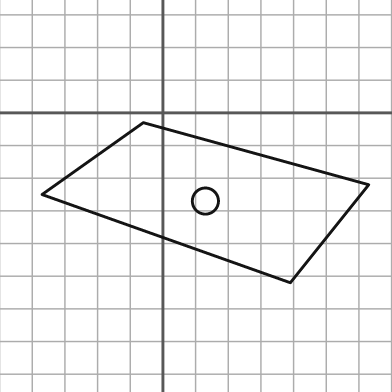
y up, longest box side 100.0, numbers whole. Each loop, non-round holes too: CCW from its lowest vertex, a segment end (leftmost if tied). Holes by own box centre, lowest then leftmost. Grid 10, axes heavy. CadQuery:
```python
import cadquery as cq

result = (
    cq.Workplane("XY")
    .moveTo(39.0, -52.0)
    .lineTo(63.0, -22.0)
    .lineTo(-6.0, -3.0)
    .lineTo(-37.0, -25.0)
    .close()
    .moveTo(13.0, -27.0)
    .circle(4.0)
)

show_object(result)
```